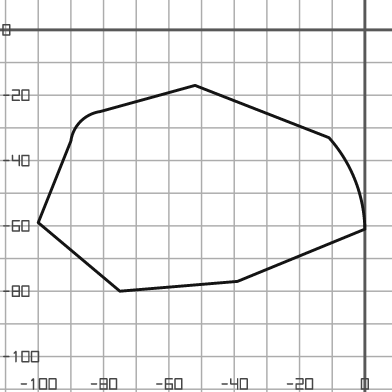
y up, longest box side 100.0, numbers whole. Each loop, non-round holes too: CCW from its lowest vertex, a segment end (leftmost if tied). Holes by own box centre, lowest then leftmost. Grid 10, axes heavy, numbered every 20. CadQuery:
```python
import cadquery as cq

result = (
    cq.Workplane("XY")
    .moveTo(-75.0, -80.0)
    .lineTo(-39.0, -77.0)
    .lineTo(0.0, -61.0)
    .threePointArc((-3.0, -46.0), (-11.0, -33.0))
    .lineTo(-52.0, -17.0)
    .lineTo(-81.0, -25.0)
    .threePointArc((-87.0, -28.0), (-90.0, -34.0))
    .lineTo(-100.0, -59.0)
    .close()
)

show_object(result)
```